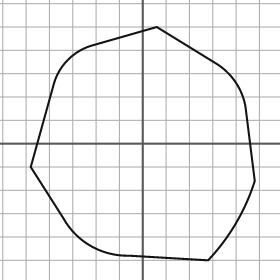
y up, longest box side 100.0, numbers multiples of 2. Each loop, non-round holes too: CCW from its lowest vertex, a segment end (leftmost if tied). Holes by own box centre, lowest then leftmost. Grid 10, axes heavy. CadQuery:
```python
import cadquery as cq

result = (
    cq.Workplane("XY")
    .moveTo(28.0, -50.0)
    .threePointArc((40.0, -34.0), (48.0, -16.0))
    .lineTo(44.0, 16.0)
    .threePointArc((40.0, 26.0), (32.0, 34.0))
    .lineTo(6.0, 50.0)
    .lineTo(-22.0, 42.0)
    .threePointArc((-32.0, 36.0), (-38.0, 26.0))
    .lineTo(-48.0, -10.0)
    .lineTo(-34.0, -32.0)
    .threePointArc((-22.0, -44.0), (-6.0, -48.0))
    .close()
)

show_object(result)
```